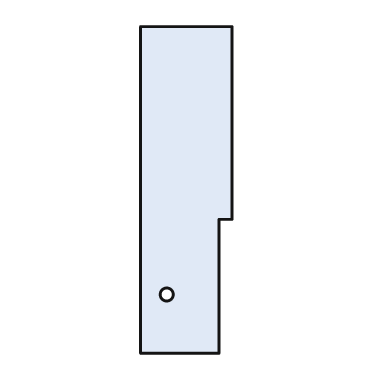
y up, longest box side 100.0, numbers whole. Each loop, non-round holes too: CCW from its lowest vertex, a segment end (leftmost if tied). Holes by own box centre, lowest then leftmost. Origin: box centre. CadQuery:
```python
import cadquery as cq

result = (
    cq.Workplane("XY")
    .moveTo(-14.0, -50.0)
    .lineTo(10.0, -50.0)
    .lineTo(10.0, -9.0)
    .lineTo(14.0, -9.0)
    .lineTo(14.0, 50.0)
    .lineTo(-14.0, 50.0)
    .close()
    .moveTo(-6.0, -32.0)
    .circle(2.0)
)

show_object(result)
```